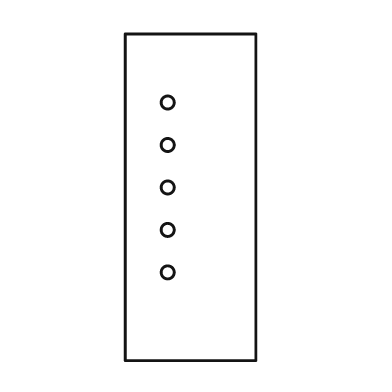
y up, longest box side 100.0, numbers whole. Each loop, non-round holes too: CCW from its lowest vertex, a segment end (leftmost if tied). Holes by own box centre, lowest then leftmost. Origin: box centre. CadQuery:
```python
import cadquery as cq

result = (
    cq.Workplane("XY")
    .moveTo(-20.0, -50.0)
    .lineTo(20.0, -50.0)
    .lineTo(20.0, 50.0)
    .lineTo(-20.0, 50.0)
    .close()
    .moveTo(-7.0, -23.0)
    .circle(2.0)
    .moveTo(-7.0, -10.0)
    .circle(2.0)
    .moveTo(-7.0, 3.0)
    .circle(2.0)
    .moveTo(-7.0, 16.0)
    .circle(2.0)
    .moveTo(-7.0, 29.0)
    .circle(2.0)
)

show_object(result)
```